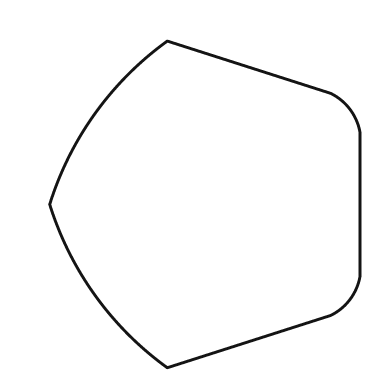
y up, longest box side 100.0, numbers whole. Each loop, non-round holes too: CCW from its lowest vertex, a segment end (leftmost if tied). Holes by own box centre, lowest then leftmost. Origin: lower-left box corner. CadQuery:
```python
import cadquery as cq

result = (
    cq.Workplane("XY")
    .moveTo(36.0, 0.0)
    .lineTo(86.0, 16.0)
    .threePointArc((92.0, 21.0), (95.0, 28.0))
    .lineTo(95.0, 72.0)
    .threePointArc((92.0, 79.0), (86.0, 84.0))
    .lineTo(36.0, 100.0)
    .threePointArc((14.0, 78.0), (0.0, 50.0))
    .threePointArc((14.0, 22.0), (36.0, 0.0))
    .close()
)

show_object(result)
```